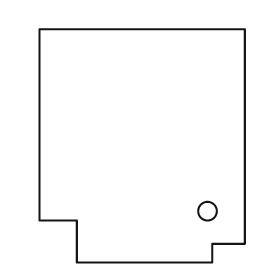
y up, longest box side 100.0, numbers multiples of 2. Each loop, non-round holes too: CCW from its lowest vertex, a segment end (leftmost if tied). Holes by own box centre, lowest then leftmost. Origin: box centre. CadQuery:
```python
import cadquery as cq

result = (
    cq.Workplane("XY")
    .moveTo(-28.0, -50.0)
    .lineTo(30.0, -50.0)
    .lineTo(30.0, -42.0)
    .lineTo(44.0, -42.0)
    .lineTo(44.0, 50.0)
    .lineTo(-44.0, 50.0)
    .lineTo(-44.0, -32.0)
    .lineTo(-28.0, -32.0)
    .close()
    .moveTo(28.0, -28.0)
    .circle(4.0)
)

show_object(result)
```